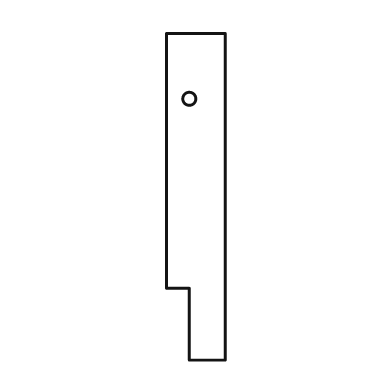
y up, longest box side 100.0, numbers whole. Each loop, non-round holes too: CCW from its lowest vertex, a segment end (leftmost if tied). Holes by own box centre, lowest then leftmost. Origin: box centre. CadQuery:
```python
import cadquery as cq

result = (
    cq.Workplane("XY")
    .moveTo(-2.0, -50.0)
    .lineTo(9.0, -50.0)
    .lineTo(9.0, 50.0)
    .lineTo(-9.0, 50.0)
    .lineTo(-9.0, -28.0)
    .lineTo(-2.0, -28.0)
    .close()
    .moveTo(-2.0, 30.0)
    .circle(2.0)
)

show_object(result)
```